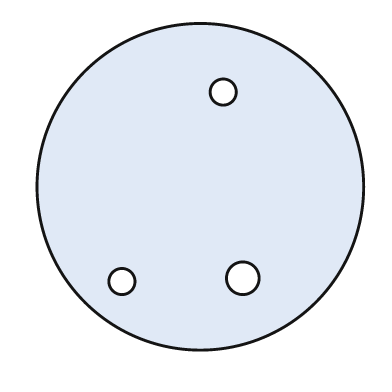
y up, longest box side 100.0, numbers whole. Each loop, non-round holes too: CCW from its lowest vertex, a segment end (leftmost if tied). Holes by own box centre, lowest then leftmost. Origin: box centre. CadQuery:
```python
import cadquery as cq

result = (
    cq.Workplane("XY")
    .moveTo(0.0, 0.0)
    .circle(50.0)
    .moveTo(-24.0, -29.0)
    .circle(4.0)
    .moveTo(13.0, -28.0)
    .circle(5.0)
    .moveTo(7.0, 29.0)
    .circle(4.0)
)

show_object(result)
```